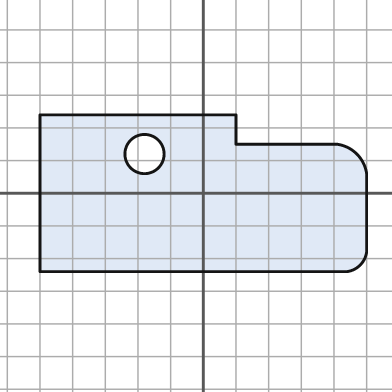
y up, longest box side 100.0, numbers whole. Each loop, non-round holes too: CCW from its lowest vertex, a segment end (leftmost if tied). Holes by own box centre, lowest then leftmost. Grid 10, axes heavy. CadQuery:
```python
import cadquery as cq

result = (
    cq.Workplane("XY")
    .moveTo(-50.0, -24.0)
    .lineTo(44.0, -24.0)
    .threePointArc((48.0, -22.0), (50.0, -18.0))
    .lineTo(50.0, 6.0)
    .threePointArc((47.0, 12.0), (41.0, 15.0))
    .lineTo(10.0, 15.0)
    .lineTo(10.0, 24.0)
    .lineTo(-50.0, 24.0)
    .close()
    .moveTo(-18.0, 12.0)
    .circle(6.0)
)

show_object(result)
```